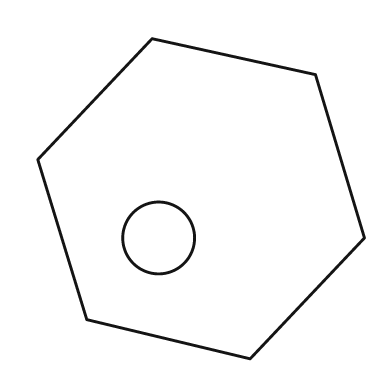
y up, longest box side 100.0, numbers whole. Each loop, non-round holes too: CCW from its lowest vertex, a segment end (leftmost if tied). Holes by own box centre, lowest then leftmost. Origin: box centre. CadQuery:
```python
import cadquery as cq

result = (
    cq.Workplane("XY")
    .moveTo(15.0, -49.0)
    .lineTo(50.0, -12.0)
    .lineTo(35.0, 38.0)
    .lineTo(-15.0, 49.0)
    .lineTo(-50.0, 12.0)
    .lineTo(-35.0, -37.0)
    .close()
    .moveTo(-13.0, -12.0)
    .circle(11.0)
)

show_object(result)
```